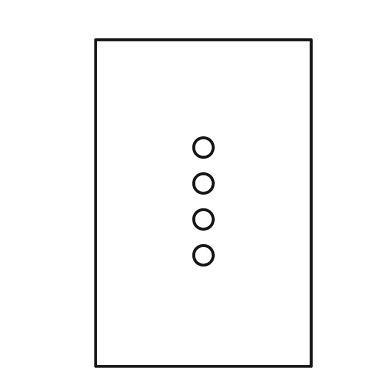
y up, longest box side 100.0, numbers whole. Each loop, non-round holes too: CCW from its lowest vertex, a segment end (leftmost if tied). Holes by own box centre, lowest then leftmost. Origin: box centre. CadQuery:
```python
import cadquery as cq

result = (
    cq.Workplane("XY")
    .moveTo(-33.0, -50.0)
    .lineTo(33.0, -50.0)
    .lineTo(33.0, 50.0)
    .lineTo(-33.0, 50.0)
    .close()
    .moveTo(0.0, -16.0)
    .circle(3.0)
    .moveTo(0.0, -5.0)
    .circle(3.0)
    .moveTo(0.0, 6.0)
    .circle(3.0)
    .moveTo(0.0, 17.0)
    .circle(3.0)
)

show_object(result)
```